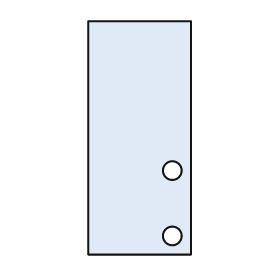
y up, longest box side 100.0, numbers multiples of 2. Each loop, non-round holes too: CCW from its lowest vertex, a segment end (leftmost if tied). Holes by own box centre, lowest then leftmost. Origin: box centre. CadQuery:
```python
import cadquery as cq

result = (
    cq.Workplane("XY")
    .moveTo(-22.0, -50.0)
    .lineTo(22.0, -50.0)
    .lineTo(22.0, 50.0)
    .lineTo(-22.0, 50.0)
    .close()
    .moveTo(14.0, -42.0)
    .circle(4.0)
    .moveTo(14.0, -14.0)
    .circle(4.0)
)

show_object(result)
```